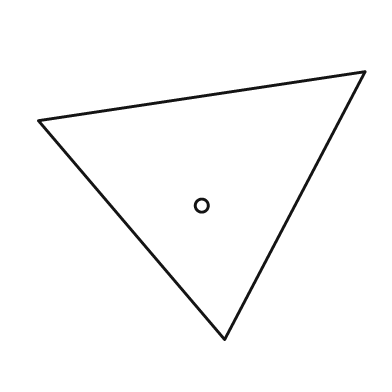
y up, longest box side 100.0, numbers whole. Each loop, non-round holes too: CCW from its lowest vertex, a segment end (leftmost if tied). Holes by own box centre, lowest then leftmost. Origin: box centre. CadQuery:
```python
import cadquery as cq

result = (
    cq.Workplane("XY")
    .moveTo(7.0, -41.0)
    .lineTo(50.0, 41.0)
    .lineTo(-50.0, 26.0)
    .close()
    .moveTo(0.0, 0.0)
    .circle(2.0)
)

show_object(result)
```